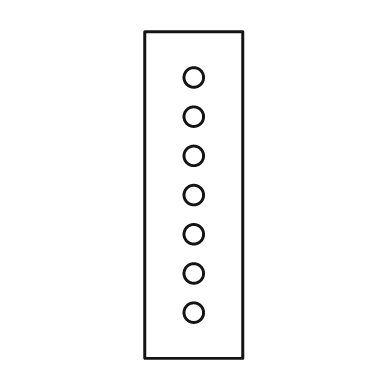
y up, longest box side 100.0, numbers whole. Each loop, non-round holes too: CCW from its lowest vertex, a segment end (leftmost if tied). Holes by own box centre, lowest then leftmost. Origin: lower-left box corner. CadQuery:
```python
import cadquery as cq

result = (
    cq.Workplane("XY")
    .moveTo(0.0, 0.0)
    .lineTo(30.0, 0.0)
    .lineTo(30.0, 100.0)
    .lineTo(0.0, 100.0)
    .close()
    .moveTo(15.0, 14.0)
    .circle(3.0)
    .moveTo(15.0, 26.0)
    .circle(3.0)
    .moveTo(15.0, 38.0)
    .circle(3.0)
    .moveTo(15.0, 50.0)
    .circle(3.0)
    .moveTo(15.0, 62.0)
    .circle(3.0)
    .moveTo(15.0, 74.0)
    .circle(3.0)
    .moveTo(15.0, 86.0)
    .circle(3.0)
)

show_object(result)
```